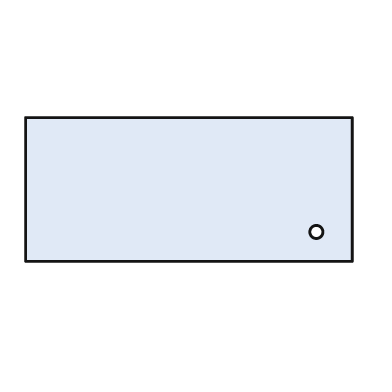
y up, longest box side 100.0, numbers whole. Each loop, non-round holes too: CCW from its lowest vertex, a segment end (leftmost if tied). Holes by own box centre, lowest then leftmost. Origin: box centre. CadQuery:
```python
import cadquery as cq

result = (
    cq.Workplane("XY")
    .moveTo(-50.0, -22.0)
    .lineTo(50.0, -22.0)
    .lineTo(50.0, 22.0)
    .lineTo(-50.0, 22.0)
    .close()
    .moveTo(39.0, -13.0)
    .circle(2.0)
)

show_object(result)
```